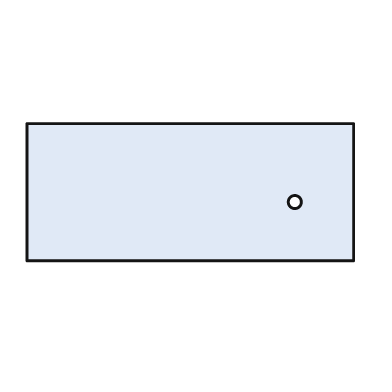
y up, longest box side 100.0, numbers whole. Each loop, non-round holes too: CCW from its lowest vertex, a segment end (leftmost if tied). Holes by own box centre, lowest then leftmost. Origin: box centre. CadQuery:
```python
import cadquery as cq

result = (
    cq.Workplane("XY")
    .moveTo(-50.0, -21.0)
    .lineTo(50.0, -21.0)
    .lineTo(50.0, 21.0)
    .lineTo(-50.0, 21.0)
    .close()
    .moveTo(32.0, -3.0)
    .circle(2.0)
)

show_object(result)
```